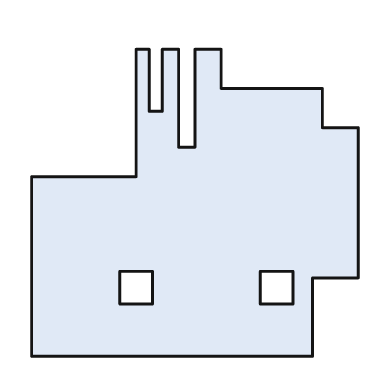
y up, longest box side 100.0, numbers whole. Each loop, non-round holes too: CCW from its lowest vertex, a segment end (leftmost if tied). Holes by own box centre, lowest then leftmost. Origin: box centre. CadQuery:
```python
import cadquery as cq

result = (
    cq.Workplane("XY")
    .moveTo(-50.0, -47.0)
    .lineTo(36.0, -47.0)
    .lineTo(36.0, -23.0)
    .lineTo(50.0, -23.0)
    .lineTo(50.0, 23.0)
    .lineTo(39.0, 23.0)
    .lineTo(39.0, 35.0)
    .lineTo(8.0, 35.0)
    .lineTo(8.0, 47.0)
    .lineTo(0.0, 47.0)
    .lineTo(0.0, 17.0)
    .lineTo(-5.0, 17.0)
    .lineTo(-5.0, 47.0)
    .lineTo(-10.0, 47.0)
    .lineTo(-10.0, 28.0)
    .lineTo(-14.0, 28.0)
    .lineTo(-14.0, 47.0)
    .lineTo(-18.0, 47.0)
    .lineTo(-18.0, 8.0)
    .lineTo(-50.0, 8.0)
    .close()
    .moveTo(-23.0, -31.0)
    .lineTo(-13.0, -31.0)
    .lineTo(-13.0, -21.0)
    .lineTo(-23.0, -21.0)
    .close()
    .moveTo(20.0, -31.0)
    .lineTo(30.0, -31.0)
    .lineTo(30.0, -21.0)
    .lineTo(20.0, -21.0)
    .close()
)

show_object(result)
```